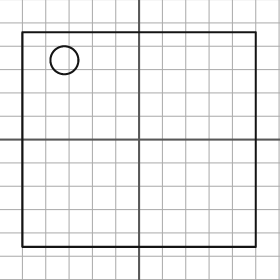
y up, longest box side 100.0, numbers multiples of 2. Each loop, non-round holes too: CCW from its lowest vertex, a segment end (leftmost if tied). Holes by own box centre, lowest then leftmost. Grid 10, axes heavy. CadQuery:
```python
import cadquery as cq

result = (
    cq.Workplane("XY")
    .moveTo(-50.0, -46.0)
    .lineTo(50.0, -46.0)
    .lineTo(50.0, 46.0)
    .lineTo(-50.0, 46.0)
    .close()
    .moveTo(-32.0, 34.0)
    .circle(6.0)
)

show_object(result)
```